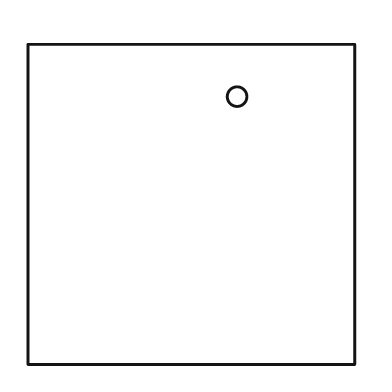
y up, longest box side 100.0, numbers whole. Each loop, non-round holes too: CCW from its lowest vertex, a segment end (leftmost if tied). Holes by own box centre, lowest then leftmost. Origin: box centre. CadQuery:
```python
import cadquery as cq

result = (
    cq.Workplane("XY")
    .moveTo(-50.0, -49.0)
    .lineTo(50.0, -49.0)
    .lineTo(50.0, 49.0)
    .lineTo(-50.0, 49.0)
    .close()
    .moveTo(14.0, 33.0)
    .circle(3.0)
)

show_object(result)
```